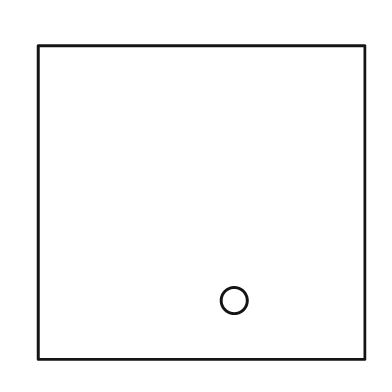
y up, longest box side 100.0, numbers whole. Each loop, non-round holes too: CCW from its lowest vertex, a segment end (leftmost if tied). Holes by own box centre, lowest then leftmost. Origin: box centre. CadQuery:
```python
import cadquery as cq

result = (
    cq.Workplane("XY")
    .moveTo(-50.0, -48.0)
    .lineTo(50.0, -48.0)
    .lineTo(50.0, 48.0)
    .lineTo(-50.0, 48.0)
    .close()
    .moveTo(10.0, -30.0)
    .circle(4.0)
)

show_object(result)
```